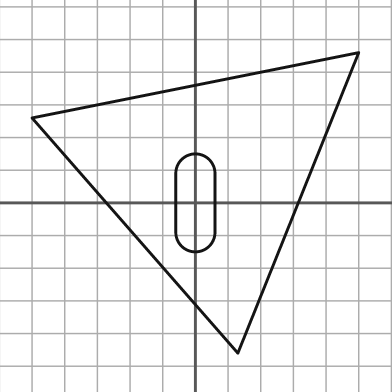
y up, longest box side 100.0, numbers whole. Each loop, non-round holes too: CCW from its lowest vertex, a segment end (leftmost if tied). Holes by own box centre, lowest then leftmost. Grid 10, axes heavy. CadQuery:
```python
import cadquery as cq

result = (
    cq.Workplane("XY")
    .moveTo(13.0, -46.0)
    .lineTo(50.0, 46.0)
    .lineTo(-50.0, 26.0)
    .close()
    .moveTo(-6.0, -9.0)
    .threePointArc((0.0, -15.0), (6.0, -9.0))
    .lineTo(6.0, 9.0)
    .threePointArc((0.0, 15.0), (-6.0, 9.0))
    .close()
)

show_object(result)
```